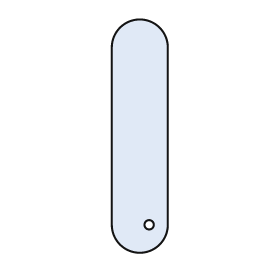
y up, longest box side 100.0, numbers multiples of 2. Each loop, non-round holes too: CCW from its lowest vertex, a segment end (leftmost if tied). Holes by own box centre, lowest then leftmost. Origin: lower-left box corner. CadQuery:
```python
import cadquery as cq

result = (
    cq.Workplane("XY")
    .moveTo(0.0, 12.0)
    .threePointArc((12.0, 0.0), (24.0, 12.0))
    .lineTo(24.0, 88.0)
    .threePointArc((12.0, 100.0), (0.0, 88.0))
    .close()
    .moveTo(16.0, 12.0)
    .circle(2.0)
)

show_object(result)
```